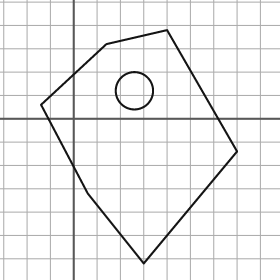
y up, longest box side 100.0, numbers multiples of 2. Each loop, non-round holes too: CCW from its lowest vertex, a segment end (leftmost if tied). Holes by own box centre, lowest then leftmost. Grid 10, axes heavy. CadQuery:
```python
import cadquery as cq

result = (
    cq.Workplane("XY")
    .moveTo(30.0, -62.0)
    .lineTo(70.0, -14.0)
    .lineTo(40.0, 38.0)
    .lineTo(14.0, 32.0)
    .lineTo(-14.0, 6.0)
    .lineTo(6.0, -32.0)
    .close()
    .moveTo(26.0, 12.0)
    .circle(8.0)
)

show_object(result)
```